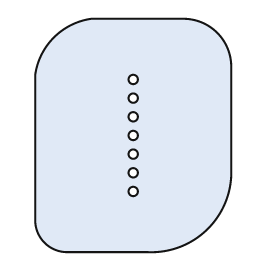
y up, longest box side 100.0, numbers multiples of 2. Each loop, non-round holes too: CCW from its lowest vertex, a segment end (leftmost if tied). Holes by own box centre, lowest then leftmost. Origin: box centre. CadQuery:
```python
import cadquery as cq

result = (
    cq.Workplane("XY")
    .moveTo(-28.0, -50.0)
    .lineTo(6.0, -50.0)
    .threePointArc((32.0, -40.0), (42.0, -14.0))
    .lineTo(42.0, 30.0)
    .threePointArc((36.0, 44.0), (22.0, 50.0))
    .lineTo(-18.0, 50.0)
    .threePointArc((-34.0, 42.0), (-42.0, 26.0))
    .lineTo(-42.0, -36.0)
    .threePointArc((-38.0, -46.0), (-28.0, -50.0))
    .close()
    .moveTo(0.0, -24.0)
    .circle(2.0)
    .moveTo(0.0, -16.0)
    .circle(2.0)
    .moveTo(0.0, -8.0)
    .circle(2.0)
    .moveTo(0.0, 0.0)
    .circle(2.0)
    .moveTo(0.0, 8.0)
    .circle(2.0)
    .moveTo(0.0, 16.0)
    .circle(2.0)
    .moveTo(0.0, 24.0)
    .circle(2.0)
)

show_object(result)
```